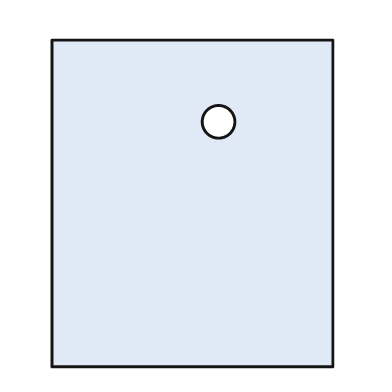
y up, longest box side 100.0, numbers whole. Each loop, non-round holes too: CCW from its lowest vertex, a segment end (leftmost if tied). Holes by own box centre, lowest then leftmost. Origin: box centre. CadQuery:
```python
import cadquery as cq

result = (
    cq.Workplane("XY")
    .moveTo(-43.0, -50.0)
    .lineTo(43.0, -50.0)
    .lineTo(43.0, 50.0)
    .lineTo(-43.0, 50.0)
    .close()
    .moveTo(8.0, 25.0)
    .circle(5.0)
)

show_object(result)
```